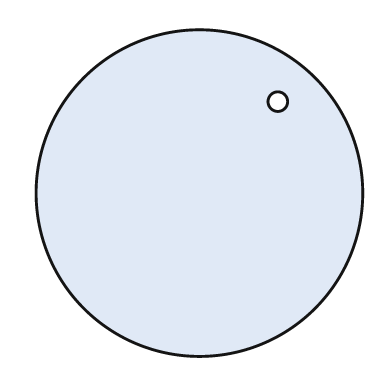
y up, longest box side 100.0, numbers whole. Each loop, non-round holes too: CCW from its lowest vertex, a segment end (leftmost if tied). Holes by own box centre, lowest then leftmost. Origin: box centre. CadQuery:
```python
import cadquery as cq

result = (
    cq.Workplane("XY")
    .moveTo(0.0, 0.0)
    .circle(50.0)
    .moveTo(24.0, 28.0)
    .circle(3.0)
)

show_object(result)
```